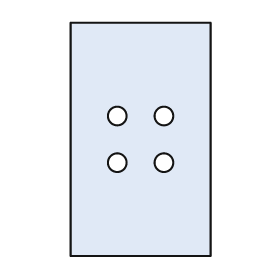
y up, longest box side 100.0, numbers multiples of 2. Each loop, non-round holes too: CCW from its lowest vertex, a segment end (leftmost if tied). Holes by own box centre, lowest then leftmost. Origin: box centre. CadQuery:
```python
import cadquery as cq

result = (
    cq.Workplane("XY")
    .moveTo(-30.0, -50.0)
    .lineTo(30.0, -50.0)
    .lineTo(30.0, 50.0)
    .lineTo(-30.0, 50.0)
    .close()
    .moveTo(-10.0, -10.0)
    .circle(4.0)
    .moveTo(10.0, -10.0)
    .circle(4.0)
    .moveTo(-10.0, 10.0)
    .circle(4.0)
    .moveTo(10.0, 10.0)
    .circle(4.0)
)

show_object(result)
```